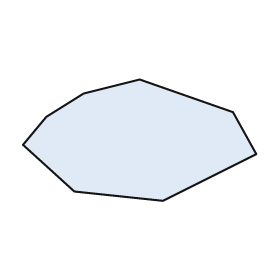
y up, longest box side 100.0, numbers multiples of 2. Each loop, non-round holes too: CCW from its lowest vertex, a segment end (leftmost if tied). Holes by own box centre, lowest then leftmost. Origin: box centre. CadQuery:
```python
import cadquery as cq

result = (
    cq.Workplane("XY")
    .moveTo(10.0, -26.0)
    .lineTo(50.0, -6.0)
    .lineTo(40.0, 12.0)
    .lineTo(0.0, 26.0)
    .lineTo(-24.0, 20.0)
    .lineTo(-40.0, 10.0)
    .lineTo(-50.0, -2.0)
    .lineTo(-28.0, -22.0)
    .close()
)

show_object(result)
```